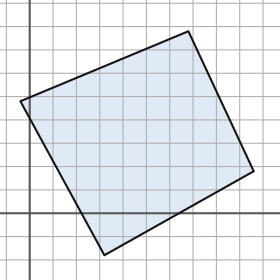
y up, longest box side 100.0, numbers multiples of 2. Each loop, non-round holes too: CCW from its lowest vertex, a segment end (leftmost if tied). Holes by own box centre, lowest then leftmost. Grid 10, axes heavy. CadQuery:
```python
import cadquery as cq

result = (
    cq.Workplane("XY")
    .moveTo(32.0, -18.0)
    .lineTo(96.0, 18.0)
    .lineTo(68.0, 78.0)
    .lineTo(-4.0, 48.0)
    .close()
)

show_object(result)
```